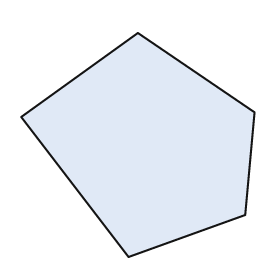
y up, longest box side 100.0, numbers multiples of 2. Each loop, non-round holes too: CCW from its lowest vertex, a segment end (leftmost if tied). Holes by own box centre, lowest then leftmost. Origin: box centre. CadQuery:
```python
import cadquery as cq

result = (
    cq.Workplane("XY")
    .moveTo(-4.0, -48.0)
    .lineTo(46.0, -30.0)
    .lineTo(50.0, 14.0)
    .lineTo(0.0, 48.0)
    .lineTo(-50.0, 12.0)
    .close()
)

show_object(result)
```